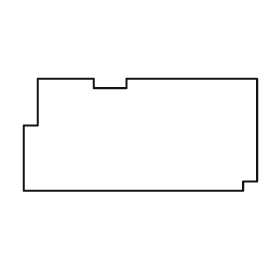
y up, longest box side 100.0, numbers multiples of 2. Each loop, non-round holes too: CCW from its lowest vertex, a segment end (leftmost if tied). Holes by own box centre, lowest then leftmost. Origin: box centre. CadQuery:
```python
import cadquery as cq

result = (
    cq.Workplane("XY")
    .moveTo(-50.0, -24.0)
    .lineTo(44.0, -24.0)
    .lineTo(44.0, -20.0)
    .lineTo(50.0, -20.0)
    .lineTo(50.0, 24.0)
    .lineTo(-6.0, 24.0)
    .lineTo(-6.0, 20.0)
    .lineTo(-20.0, 20.0)
    .lineTo(-20.0, 24.0)
    .lineTo(-44.0, 24.0)
    .lineTo(-44.0, 4.0)
    .lineTo(-50.0, 4.0)
    .close()
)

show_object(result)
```